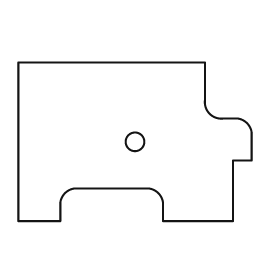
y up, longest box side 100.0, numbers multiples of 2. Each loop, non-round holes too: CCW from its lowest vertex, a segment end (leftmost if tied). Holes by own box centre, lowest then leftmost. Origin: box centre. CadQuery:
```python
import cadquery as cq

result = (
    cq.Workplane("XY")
    .moveTo(-50.0, -34.0)
    .lineTo(-32.0, -34.0)
    .lineTo(-32.0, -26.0)
    .threePointArc((-30.0, -22.0), (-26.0, -20.0))
    .lineTo(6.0, -20.0)
    .threePointArc((10.0, -22.0), (12.0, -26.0))
    .lineTo(12.0, -34.0)
    .lineTo(42.0, -34.0)
    .lineTo(42.0, -8.0)
    .lineTo(50.0, -8.0)
    .lineTo(50.0, 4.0)
    .threePointArc((48.0, 8.0), (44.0, 10.0))
    .lineTo(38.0, 10.0)
    .threePointArc((32.0, 12.0), (30.0, 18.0))
    .lineTo(30.0, 34.0)
    .lineTo(-50.0, 34.0)
    .close()
    .moveTo(0.0, 0.0)
    .circle(4.0)
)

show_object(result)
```